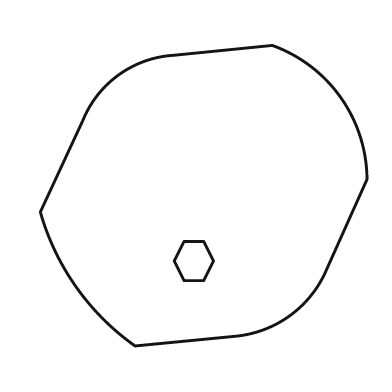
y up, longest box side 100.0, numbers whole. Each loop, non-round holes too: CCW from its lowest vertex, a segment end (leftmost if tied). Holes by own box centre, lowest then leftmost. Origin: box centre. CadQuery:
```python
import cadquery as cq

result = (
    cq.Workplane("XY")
    .moveTo(-21.0, -46.0)
    .lineTo(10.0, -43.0)
    .threePointArc((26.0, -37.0), (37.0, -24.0))
    .lineTo(50.0, 5.0)
    .threePointArc((42.0, 30.0), (21.0, 46.0))
    .lineTo(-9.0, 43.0)
    .threePointArc((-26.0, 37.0), (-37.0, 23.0))
    .lineTo(-50.0, -5.0)
    .threePointArc((-39.0, -28.0), (-21.0, -46.0))
    .close()
    .moveTo(-6.0, -26.0)
    .lineTo(0.0, -26.0)
    .lineTo(3.0, -20.0)
    .lineTo(0.0, -14.0)
    .lineTo(-6.0, -14.0)
    .lineTo(-9.0, -20.0)
    .close()
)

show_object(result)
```